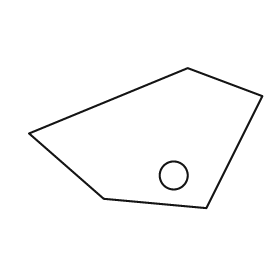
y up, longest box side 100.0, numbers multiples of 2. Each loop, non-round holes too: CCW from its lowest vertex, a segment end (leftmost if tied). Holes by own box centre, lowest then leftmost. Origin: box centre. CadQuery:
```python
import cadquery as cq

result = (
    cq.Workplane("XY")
    .moveTo(26.0, -30.0)
    .lineTo(50.0, 18.0)
    .lineTo(18.0, 30.0)
    .lineTo(-50.0, 2.0)
    .lineTo(-18.0, -26.0)
    .close()
    .moveTo(12.0, -16.0)
    .circle(6.0)
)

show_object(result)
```